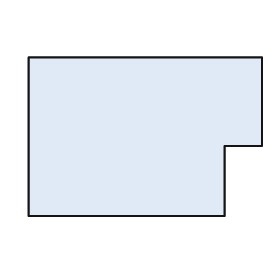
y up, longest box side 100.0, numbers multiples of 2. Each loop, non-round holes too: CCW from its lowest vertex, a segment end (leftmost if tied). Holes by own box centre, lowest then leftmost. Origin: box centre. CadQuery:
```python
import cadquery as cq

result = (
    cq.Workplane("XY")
    .moveTo(-50.0, -34.0)
    .lineTo(34.0, -34.0)
    .lineTo(34.0, -4.0)
    .lineTo(50.0, -4.0)
    .lineTo(50.0, 34.0)
    .lineTo(-50.0, 34.0)
    .close()
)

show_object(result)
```